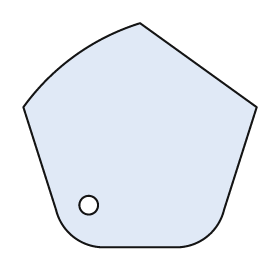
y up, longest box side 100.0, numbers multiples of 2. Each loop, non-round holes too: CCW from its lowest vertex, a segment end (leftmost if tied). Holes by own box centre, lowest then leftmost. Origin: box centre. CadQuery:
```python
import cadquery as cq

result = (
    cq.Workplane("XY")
    .moveTo(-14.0, -48.0)
    .lineTo(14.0, -48.0)
    .threePointArc((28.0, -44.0), (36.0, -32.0))
    .lineTo(50.0, 12.0)
    .lineTo(0.0, 48.0)
    .threePointArc((-28.0, 34.0), (-50.0, 12.0))
    .lineTo(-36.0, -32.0)
    .threePointArc((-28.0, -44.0), (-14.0, -48.0))
    .close()
    .moveTo(-22.0, -30.0)
    .circle(4.0)
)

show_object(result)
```